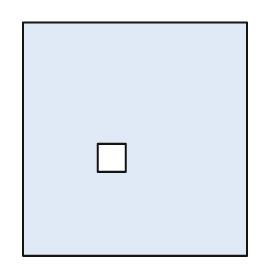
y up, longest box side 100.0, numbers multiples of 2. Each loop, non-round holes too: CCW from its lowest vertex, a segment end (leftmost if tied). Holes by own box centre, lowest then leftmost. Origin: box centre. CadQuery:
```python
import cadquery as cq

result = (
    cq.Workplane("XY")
    .moveTo(-48.0, -50.0)
    .lineTo(48.0, -50.0)
    .lineTo(48.0, 50.0)
    .lineTo(-48.0, 50.0)
    .close()
    .moveTo(-16.0, -14.0)
    .lineTo(-4.0, -14.0)
    .lineTo(-4.0, -2.0)
    .lineTo(-16.0, -2.0)
    .close()
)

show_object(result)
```